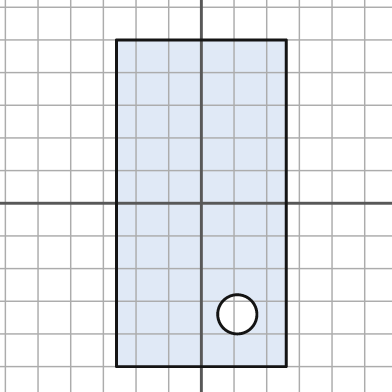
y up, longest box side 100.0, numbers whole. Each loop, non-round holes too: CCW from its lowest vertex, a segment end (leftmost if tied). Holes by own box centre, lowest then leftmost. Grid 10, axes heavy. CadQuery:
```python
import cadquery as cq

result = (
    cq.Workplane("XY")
    .moveTo(-26.0, -50.0)
    .lineTo(26.0, -50.0)
    .lineTo(26.0, 50.0)
    .lineTo(-26.0, 50.0)
    .close()
    .moveTo(11.0, -34.0)
    .circle(6.0)
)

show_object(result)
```